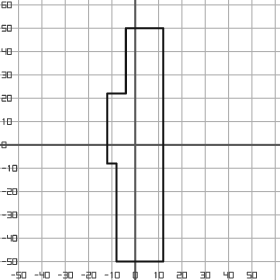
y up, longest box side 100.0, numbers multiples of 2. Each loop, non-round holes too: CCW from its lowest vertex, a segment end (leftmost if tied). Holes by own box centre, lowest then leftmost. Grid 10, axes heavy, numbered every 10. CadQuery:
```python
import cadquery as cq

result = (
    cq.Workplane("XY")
    .moveTo(-8.0, -50.0)
    .lineTo(12.0, -50.0)
    .lineTo(12.0, 50.0)
    .lineTo(-4.0, 50.0)
    .lineTo(-4.0, 22.0)
    .lineTo(-12.0, 22.0)
    .lineTo(-12.0, -8.0)
    .lineTo(-8.0, -8.0)
    .close()
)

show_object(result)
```